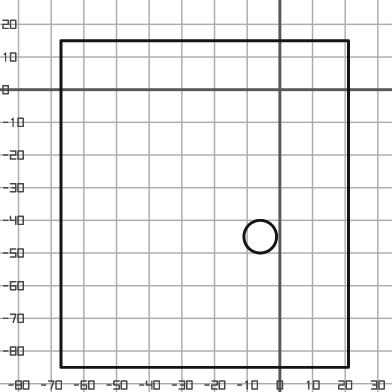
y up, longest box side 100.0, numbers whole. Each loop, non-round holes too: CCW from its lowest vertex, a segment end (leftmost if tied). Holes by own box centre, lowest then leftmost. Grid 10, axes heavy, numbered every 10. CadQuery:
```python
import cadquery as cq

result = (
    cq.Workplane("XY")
    .moveTo(-67.0, -85.0)
    .lineTo(21.0, -85.0)
    .lineTo(21.0, 15.0)
    .lineTo(-67.0, 15.0)
    .close()
    .moveTo(-6.0, -45.0)
    .circle(5.0)
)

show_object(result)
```